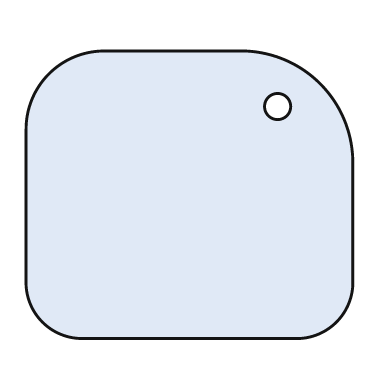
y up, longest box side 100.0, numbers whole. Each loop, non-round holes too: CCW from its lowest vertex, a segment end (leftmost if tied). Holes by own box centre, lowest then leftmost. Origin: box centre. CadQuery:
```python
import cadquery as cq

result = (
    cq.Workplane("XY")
    .moveTo(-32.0, -44.0)
    .lineTo(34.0, -44.0)
    .threePointArc((45.0, -39.0), (50.0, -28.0))
    .lineTo(50.0, 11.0)
    .threePointArc((40.0, 34.0), (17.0, 44.0))
    .lineTo(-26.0, 44.0)
    .threePointArc((-43.0, 37.0), (-50.0, 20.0))
    .lineTo(-50.0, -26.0)
    .threePointArc((-45.0, -39.0), (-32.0, -44.0))
    .close()
    .moveTo(27.0, 27.0)
    .circle(4.0)
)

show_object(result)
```